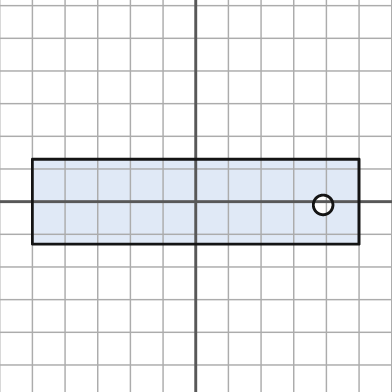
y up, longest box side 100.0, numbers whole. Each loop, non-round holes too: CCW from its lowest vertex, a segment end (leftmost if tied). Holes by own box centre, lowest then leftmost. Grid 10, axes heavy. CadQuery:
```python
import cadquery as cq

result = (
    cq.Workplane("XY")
    .moveTo(-50.0, -13.0)
    .lineTo(50.0, -13.0)
    .lineTo(50.0, 13.0)
    .lineTo(-50.0, 13.0)
    .close()
    .moveTo(39.0, -1.0)
    .circle(3.0)
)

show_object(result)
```